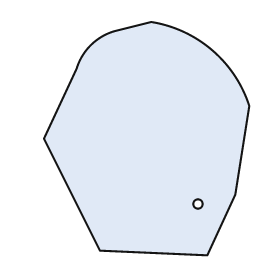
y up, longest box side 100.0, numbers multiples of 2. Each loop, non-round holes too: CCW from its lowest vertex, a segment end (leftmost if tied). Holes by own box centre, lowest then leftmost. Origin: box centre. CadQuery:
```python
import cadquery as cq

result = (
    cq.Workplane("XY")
    .moveTo(26.0, -50.0)
    .lineTo(38.0, -24.0)
    .lineTo(44.0, 14.0)
    .threePointArc((28.0, 38.0), (2.0, 50.0))
    .lineTo(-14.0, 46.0)
    .threePointArc((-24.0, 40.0), (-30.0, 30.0))
    .lineTo(-44.0, 0.0)
    .lineTo(-20.0, -48.0)
    .close()
    .moveTo(22.0, -28.0)
    .circle(2.0)
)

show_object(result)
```